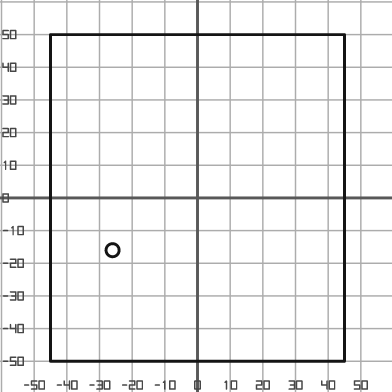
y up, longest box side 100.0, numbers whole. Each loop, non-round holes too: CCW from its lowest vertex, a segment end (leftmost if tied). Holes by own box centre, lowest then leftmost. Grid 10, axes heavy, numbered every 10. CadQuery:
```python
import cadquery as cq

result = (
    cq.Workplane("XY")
    .moveTo(-45.0, -50.0)
    .lineTo(45.0, -50.0)
    .lineTo(45.0, 50.0)
    .lineTo(-45.0, 50.0)
    .close()
    .moveTo(-26.0, -16.0)
    .circle(2.0)
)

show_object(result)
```